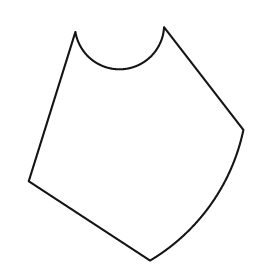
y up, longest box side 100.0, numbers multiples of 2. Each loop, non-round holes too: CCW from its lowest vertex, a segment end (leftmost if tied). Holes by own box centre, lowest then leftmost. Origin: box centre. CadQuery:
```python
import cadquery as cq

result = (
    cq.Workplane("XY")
    .moveTo(6.0, -50.0)
    .threePointArc((32.0, -26.0), (46.0, 6.0))
    .lineTo(12.0, 50.0)
    .threePointArc((-6.0, 32.0), (-26.0, 48.0))
    .lineTo(-46.0, -16.0)
    .close()
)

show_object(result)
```